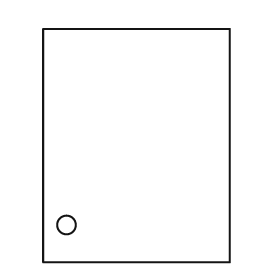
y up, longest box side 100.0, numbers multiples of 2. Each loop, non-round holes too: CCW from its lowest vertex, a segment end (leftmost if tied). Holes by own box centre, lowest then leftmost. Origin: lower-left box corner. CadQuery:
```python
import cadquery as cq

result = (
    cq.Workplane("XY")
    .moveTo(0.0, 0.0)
    .lineTo(80.0, 0.0)
    .lineTo(80.0, 100.0)
    .lineTo(0.0, 100.0)
    .close()
    .moveTo(10.0, 16.0)
    .circle(4.0)
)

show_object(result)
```